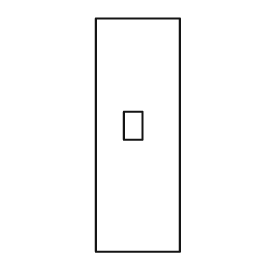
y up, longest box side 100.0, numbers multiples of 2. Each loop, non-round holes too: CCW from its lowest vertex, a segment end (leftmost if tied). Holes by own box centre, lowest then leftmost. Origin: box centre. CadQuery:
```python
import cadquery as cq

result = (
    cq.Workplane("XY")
    .moveTo(-18.0, -50.0)
    .lineTo(18.0, -50.0)
    .lineTo(18.0, 50.0)
    .lineTo(-18.0, 50.0)
    .close()
    .moveTo(-6.0, -2.0)
    .lineTo(2.0, -2.0)
    .lineTo(2.0, 10.0)
    .lineTo(-6.0, 10.0)
    .close()
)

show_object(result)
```